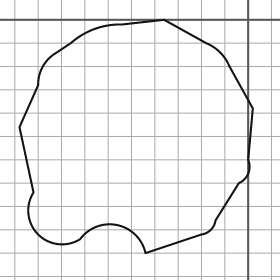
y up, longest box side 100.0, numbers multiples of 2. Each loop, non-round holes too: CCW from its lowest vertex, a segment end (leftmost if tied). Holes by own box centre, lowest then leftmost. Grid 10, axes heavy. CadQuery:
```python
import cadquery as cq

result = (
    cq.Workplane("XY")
    .moveTo(-44.0, -100.0)
    .lineTo(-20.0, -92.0)
    .threePointArc((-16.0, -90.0), (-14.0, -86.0))
    .lineTo(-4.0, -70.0)
    .threePointArc((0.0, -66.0), (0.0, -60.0))
    .lineTo(2.0, -38.0)
    .lineTo(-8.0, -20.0)
    .threePointArc((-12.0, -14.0), (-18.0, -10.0))
    .lineTo(-36.0, 0.0)
    .lineTo(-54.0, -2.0)
    .threePointArc((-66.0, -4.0), (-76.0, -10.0))
    .lineTo(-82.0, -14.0)
    .threePointArc((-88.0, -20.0), (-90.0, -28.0))
    .lineTo(-98.0, -46.0)
    .lineTo(-92.0, -74.0)
    .threePointArc((-90.0, -92.0), (-72.0, -94.0))
    .threePointArc((-56.0, -88.0), (-44.0, -100.0))
    .close()
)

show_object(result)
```